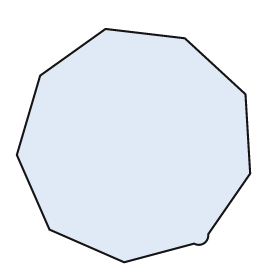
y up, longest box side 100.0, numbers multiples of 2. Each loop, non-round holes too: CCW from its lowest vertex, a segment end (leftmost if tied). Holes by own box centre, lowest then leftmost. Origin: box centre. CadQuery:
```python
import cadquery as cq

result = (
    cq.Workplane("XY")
    .moveTo(-4.0, -50.0)
    .lineTo(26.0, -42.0)
    .threePointArc((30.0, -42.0), (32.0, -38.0))
    .lineTo(50.0, -12.0)
    .lineTo(48.0, 22.0)
    .lineTo(22.0, 46.0)
    .lineTo(-12.0, 50.0)
    .lineTo(-40.0, 30.0)
    .lineTo(-50.0, -4.0)
    .lineTo(-36.0, -36.0)
    .close()
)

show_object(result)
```